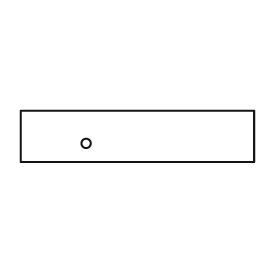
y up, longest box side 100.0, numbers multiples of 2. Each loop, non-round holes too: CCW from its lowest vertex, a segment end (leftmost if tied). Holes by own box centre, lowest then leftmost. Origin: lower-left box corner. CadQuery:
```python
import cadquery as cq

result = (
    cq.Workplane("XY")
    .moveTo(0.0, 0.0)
    .lineTo(100.0, 0.0)
    .lineTo(100.0, 22.0)
    .lineTo(0.0, 22.0)
    .close()
    .moveTo(28.0, 8.0)
    .circle(2.0)
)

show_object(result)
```